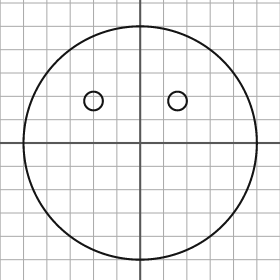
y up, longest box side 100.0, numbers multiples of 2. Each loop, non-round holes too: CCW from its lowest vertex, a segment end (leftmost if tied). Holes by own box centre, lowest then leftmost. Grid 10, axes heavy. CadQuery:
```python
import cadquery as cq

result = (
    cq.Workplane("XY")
    .moveTo(0.0, 0.0)
    .circle(50.0)
    .moveTo(-20.0, 18.0)
    .circle(4.0)
    .moveTo(16.0, 18.0)
    .circle(4.0)
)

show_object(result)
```